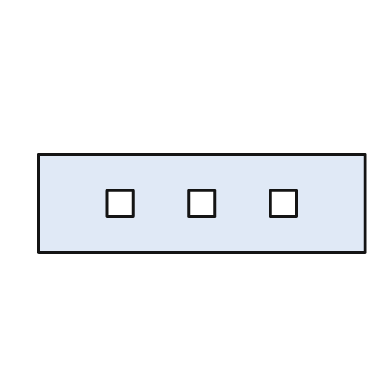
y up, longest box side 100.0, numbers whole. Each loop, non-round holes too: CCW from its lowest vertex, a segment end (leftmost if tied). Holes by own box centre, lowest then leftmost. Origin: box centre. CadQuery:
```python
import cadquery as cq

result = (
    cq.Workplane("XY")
    .moveTo(-50.0, -15.0)
    .lineTo(50.0, -15.0)
    .lineTo(50.0, 15.0)
    .lineTo(-50.0, 15.0)
    .close()
    .moveTo(-29.0, -4.0)
    .lineTo(-21.0, -4.0)
    .lineTo(-21.0, 4.0)
    .lineTo(-29.0, 4.0)
    .close()
    .moveTo(-4.0, -4.0)
    .lineTo(4.0, -4.0)
    .lineTo(4.0, 4.0)
    .lineTo(-4.0, 4.0)
    .close()
    .moveTo(21.0, -4.0)
    .lineTo(29.0, -4.0)
    .lineTo(29.0, 4.0)
    .lineTo(21.0, 4.0)
    .close()
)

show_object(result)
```